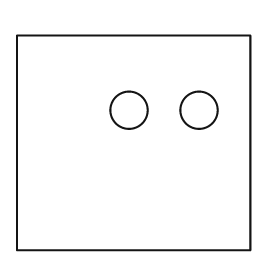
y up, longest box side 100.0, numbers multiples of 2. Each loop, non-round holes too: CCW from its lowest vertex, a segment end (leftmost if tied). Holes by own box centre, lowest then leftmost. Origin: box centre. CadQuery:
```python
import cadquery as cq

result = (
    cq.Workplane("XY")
    .moveTo(-50.0, -46.0)
    .lineTo(50.0, -46.0)
    .lineTo(50.0, 46.0)
    .lineTo(-50.0, 46.0)
    .close()
    .moveTo(-2.0, 14.0)
    .circle(8.0)
    .moveTo(28.0, 14.0)
    .circle(8.0)
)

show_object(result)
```